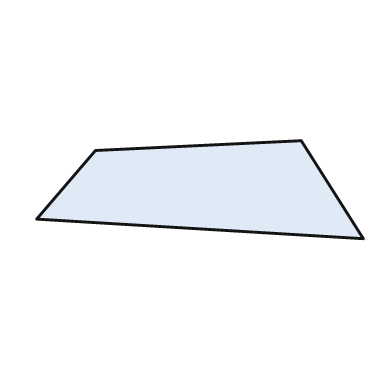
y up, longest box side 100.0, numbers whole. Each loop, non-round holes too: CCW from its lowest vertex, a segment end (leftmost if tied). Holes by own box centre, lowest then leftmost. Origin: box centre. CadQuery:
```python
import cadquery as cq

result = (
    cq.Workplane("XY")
    .moveTo(50.0, -15.0)
    .lineTo(31.0, 15.0)
    .lineTo(-32.0, 12.0)
    .lineTo(-50.0, -9.0)
    .close()
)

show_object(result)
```